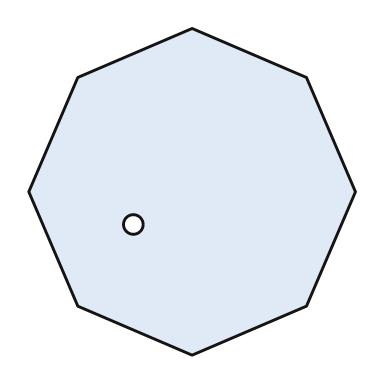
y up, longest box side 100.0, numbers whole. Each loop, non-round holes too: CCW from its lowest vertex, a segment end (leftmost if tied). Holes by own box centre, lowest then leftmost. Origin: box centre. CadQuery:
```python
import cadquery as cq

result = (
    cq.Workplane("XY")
    .moveTo(0.0, -50.0)
    .lineTo(35.0, -35.0)
    .lineTo(50.0, 0.0)
    .lineTo(35.0, 35.0)
    .lineTo(0.0, 50.0)
    .lineTo(-35.0, 35.0)
    .lineTo(-50.0, 0.0)
    .lineTo(-35.0, -35.0)
    .close()
    .moveTo(-18.0, -10.0)
    .circle(3.0)
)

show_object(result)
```